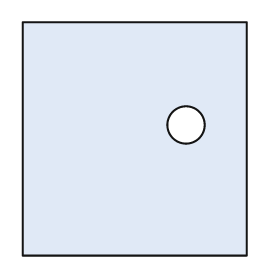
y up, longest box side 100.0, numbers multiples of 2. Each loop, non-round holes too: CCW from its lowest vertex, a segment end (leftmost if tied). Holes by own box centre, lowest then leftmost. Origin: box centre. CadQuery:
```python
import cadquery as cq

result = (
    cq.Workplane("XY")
    .moveTo(-48.0, -50.0)
    .lineTo(48.0, -50.0)
    .lineTo(48.0, 50.0)
    .lineTo(-48.0, 50.0)
    .close()
    .moveTo(22.0, 6.0)
    .circle(8.0)
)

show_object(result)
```